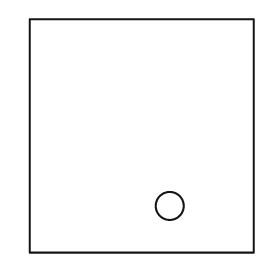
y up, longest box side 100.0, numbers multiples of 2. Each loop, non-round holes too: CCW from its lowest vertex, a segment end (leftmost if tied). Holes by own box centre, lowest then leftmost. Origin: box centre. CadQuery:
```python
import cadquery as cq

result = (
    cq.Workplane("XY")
    .moveTo(-48.0, -50.0)
    .lineTo(48.0, -50.0)
    .lineTo(48.0, 50.0)
    .lineTo(-48.0, 50.0)
    .close()
    .moveTo(12.0, -30.0)
    .circle(6.0)
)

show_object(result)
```